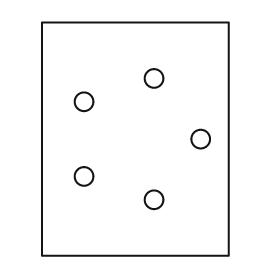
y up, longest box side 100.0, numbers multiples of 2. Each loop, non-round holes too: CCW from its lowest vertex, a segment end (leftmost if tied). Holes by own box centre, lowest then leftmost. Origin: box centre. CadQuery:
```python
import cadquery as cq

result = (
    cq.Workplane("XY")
    .moveTo(-40.0, -50.0)
    .lineTo(40.0, -50.0)
    .lineTo(40.0, 50.0)
    .lineTo(-40.0, 50.0)
    .close()
    .moveTo(8.0, -26.0)
    .circle(4.0)
    .moveTo(-22.0, -16.0)
    .circle(4.0)
    .moveTo(28.0, 0.0)
    .circle(4.0)
    .moveTo(-22.0, 16.0)
    .circle(4.0)
    .moveTo(8.0, 26.0)
    .circle(4.0)
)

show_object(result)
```